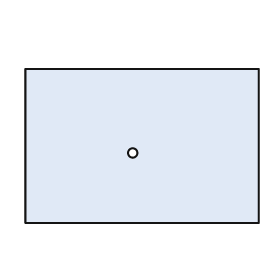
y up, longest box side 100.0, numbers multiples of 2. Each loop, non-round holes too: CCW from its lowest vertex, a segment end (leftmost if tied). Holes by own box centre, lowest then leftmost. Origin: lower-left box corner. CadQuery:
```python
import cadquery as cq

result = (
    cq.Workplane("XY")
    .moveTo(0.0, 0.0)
    .lineTo(100.0, 0.0)
    .lineTo(100.0, 66.0)
    .lineTo(0.0, 66.0)
    .close()
    .moveTo(46.0, 30.0)
    .circle(2.0)
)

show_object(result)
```